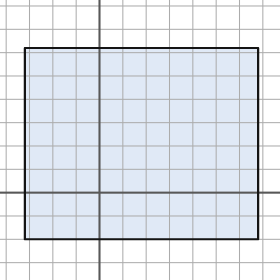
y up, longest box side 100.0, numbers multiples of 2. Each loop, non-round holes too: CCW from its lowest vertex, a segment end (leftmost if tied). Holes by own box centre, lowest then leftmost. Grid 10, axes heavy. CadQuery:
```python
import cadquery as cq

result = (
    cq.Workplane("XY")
    .moveTo(-32.0, -20.0)
    .lineTo(68.0, -20.0)
    .lineTo(68.0, 62.0)
    .lineTo(-32.0, 62.0)
    .close()
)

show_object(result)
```